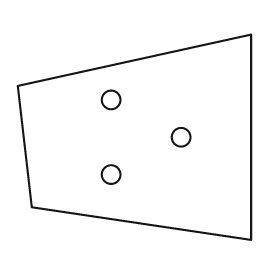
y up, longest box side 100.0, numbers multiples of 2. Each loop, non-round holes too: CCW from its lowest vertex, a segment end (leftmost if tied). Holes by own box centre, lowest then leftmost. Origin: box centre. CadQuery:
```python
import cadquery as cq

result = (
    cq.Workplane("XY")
    .moveTo(50.0, -44.0)
    .lineTo(50.0, 44.0)
    .lineTo(-50.0, 22.0)
    .lineTo(-44.0, -30.0)
    .close()
    .moveTo(-10.0, -16.0)
    .circle(4.0)
    .moveTo(20.0, 0.0)
    .circle(4.0)
    .moveTo(-10.0, 16.0)
    .circle(4.0)
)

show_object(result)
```